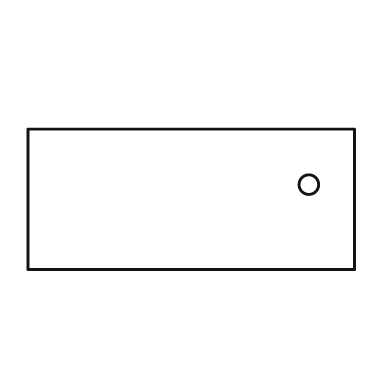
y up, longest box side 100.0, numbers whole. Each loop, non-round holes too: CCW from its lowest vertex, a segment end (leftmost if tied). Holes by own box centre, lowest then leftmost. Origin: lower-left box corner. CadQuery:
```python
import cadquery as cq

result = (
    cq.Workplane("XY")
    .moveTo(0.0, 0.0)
    .lineTo(100.0, 0.0)
    .lineTo(100.0, 43.0)
    .lineTo(0.0, 43.0)
    .close()
    .moveTo(86.0, 26.0)
    .circle(3.0)
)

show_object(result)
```